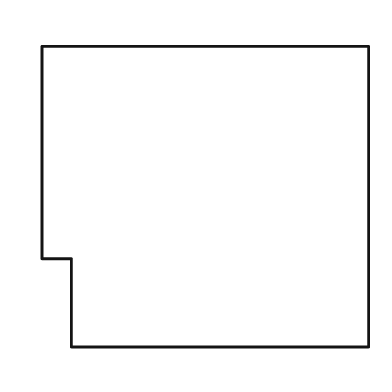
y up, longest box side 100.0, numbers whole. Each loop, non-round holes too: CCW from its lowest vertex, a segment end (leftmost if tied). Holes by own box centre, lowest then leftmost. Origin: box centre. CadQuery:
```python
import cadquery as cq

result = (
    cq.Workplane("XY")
    .moveTo(-41.0, -46.0)
    .lineTo(50.0, -46.0)
    .lineTo(50.0, 46.0)
    .lineTo(-50.0, 46.0)
    .lineTo(-50.0, -19.0)
    .lineTo(-41.0, -19.0)
    .close()
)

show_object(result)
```